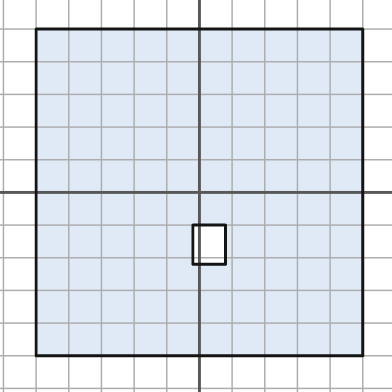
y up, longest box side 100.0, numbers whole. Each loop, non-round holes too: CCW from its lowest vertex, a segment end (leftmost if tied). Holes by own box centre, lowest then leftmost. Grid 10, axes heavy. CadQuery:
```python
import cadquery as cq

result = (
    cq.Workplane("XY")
    .moveTo(-50.0, -50.0)
    .lineTo(50.0, -50.0)
    .lineTo(50.0, 50.0)
    .lineTo(-50.0, 50.0)
    .close()
    .moveTo(-2.0, -22.0)
    .lineTo(8.0, -22.0)
    .lineTo(8.0, -10.0)
    .lineTo(-2.0, -10.0)
    .close()
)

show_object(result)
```